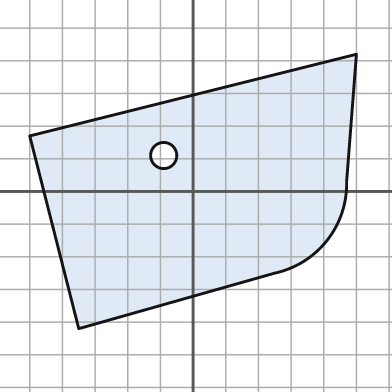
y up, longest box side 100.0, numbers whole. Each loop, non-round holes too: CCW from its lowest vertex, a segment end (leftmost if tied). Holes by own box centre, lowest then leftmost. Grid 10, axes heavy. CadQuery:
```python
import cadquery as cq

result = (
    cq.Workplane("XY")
    .moveTo(-35.0, -42.0)
    .lineTo(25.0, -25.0)
    .threePointArc((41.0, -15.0), (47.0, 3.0))
    .lineTo(50.0, 42.0)
    .lineTo(-50.0, 17.0)
    .close()
    .moveTo(-9.0, 11.0)
    .circle(4.0)
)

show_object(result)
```